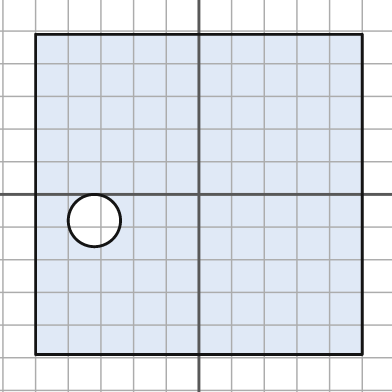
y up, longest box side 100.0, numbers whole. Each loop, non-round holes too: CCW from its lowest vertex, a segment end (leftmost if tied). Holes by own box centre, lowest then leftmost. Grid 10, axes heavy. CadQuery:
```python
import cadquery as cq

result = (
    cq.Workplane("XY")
    .moveTo(-50.0, -49.0)
    .lineTo(50.0, -49.0)
    .lineTo(50.0, 49.0)
    .lineTo(-50.0, 49.0)
    .close()
    .moveTo(-32.0, -8.0)
    .circle(8.0)
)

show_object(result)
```